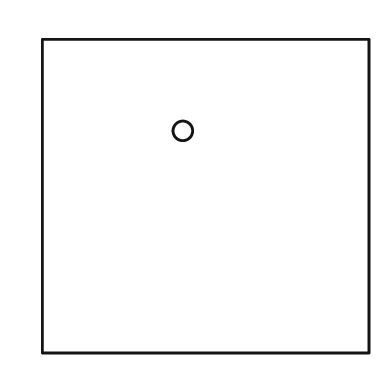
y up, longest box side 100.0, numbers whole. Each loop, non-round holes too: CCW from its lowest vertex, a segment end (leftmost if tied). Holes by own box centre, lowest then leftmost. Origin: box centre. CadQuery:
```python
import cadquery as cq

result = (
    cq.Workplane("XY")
    .moveTo(-50.0, -48.0)
    .lineTo(50.0, -48.0)
    .lineTo(50.0, 48.0)
    .lineTo(-50.0, 48.0)
    .close()
    .moveTo(-7.0, 20.0)
    .circle(3.0)
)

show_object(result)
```